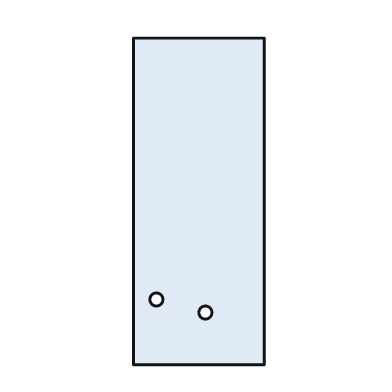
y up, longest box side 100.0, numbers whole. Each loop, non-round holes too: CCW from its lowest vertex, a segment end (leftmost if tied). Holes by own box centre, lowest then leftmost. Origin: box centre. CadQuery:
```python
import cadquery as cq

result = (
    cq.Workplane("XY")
    .moveTo(-20.0, -50.0)
    .lineTo(20.0, -50.0)
    .lineTo(20.0, 50.0)
    .lineTo(-20.0, 50.0)
    .close()
    .moveTo(2.0, -34.0)
    .circle(2.0)
    .moveTo(-13.0, -30.0)
    .circle(2.0)
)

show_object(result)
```